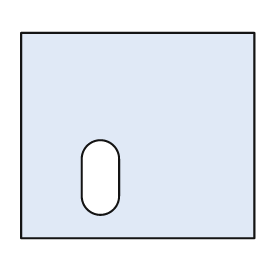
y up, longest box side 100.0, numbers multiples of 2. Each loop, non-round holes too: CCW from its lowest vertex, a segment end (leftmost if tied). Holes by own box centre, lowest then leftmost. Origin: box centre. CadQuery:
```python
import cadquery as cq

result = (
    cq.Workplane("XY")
    .moveTo(-50.0, -44.0)
    .lineTo(50.0, -44.0)
    .lineTo(50.0, 44.0)
    .lineTo(-50.0, 44.0)
    .close()
    .moveTo(-24.0, -26.0)
    .threePointArc((-16.0, -34.0), (-8.0, -26.0))
    .lineTo(-8.0, -10.0)
    .threePointArc((-16.0, -2.0), (-24.0, -10.0))
    .close()
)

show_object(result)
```